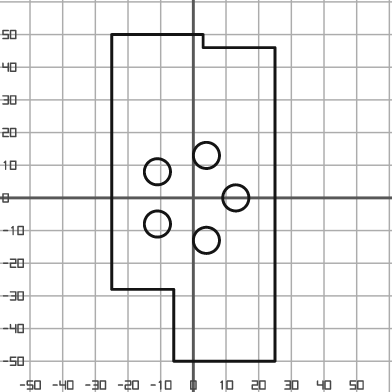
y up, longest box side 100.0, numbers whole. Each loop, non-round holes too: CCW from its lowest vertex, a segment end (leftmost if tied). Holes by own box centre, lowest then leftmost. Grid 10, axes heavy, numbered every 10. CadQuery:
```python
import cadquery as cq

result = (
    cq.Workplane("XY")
    .moveTo(-6.0, -50.0)
    .lineTo(25.0, -50.0)
    .lineTo(25.0, 46.0)
    .lineTo(3.0, 46.0)
    .lineTo(3.0, 50.0)
    .lineTo(-25.0, 50.0)
    .lineTo(-25.0, -28.0)
    .lineTo(-6.0, -28.0)
    .close()
    .moveTo(4.0, -13.0)
    .circle(4.0)
    .moveTo(-11.0, -8.0)
    .circle(4.0)
    .moveTo(13.0, 0.0)
    .circle(4.0)
    .moveTo(-11.0, 8.0)
    .circle(4.0)
    .moveTo(4.0, 13.0)
    .circle(4.0)
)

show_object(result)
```